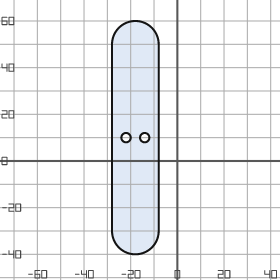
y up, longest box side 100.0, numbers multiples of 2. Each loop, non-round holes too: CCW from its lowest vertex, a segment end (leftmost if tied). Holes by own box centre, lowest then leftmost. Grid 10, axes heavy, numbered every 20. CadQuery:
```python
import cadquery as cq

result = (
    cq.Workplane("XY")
    .moveTo(-28.0, -30.0)
    .threePointArc((-18.0, -40.0), (-8.0, -30.0))
    .lineTo(-8.0, 50.0)
    .threePointArc((-18.0, 60.0), (-28.0, 50.0))
    .close()
    .moveTo(-22.0, 10.0)
    .circle(2.0)
    .moveTo(-14.0, 10.0)
    .circle(2.0)
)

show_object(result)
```